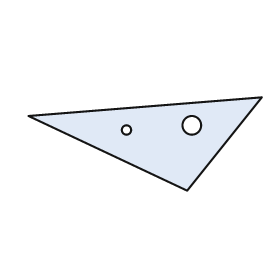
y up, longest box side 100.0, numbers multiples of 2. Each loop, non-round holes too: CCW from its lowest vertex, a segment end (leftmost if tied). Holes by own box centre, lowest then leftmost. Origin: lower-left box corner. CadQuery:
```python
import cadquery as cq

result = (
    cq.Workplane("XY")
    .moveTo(68.0, 0.0)
    .lineTo(100.0, 40.0)
    .lineTo(0.0, 32.0)
    .close()
    .moveTo(42.0, 26.0)
    .circle(2.0)
    .moveTo(70.0, 28.0)
    .circle(4.0)
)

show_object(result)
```